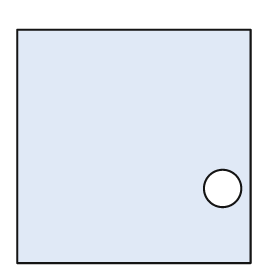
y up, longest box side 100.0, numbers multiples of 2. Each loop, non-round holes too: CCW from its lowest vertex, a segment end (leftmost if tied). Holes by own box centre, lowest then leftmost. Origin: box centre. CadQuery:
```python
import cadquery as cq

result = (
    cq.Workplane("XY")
    .moveTo(-50.0, -50.0)
    .lineTo(50.0, -50.0)
    .lineTo(50.0, 50.0)
    .lineTo(-50.0, 50.0)
    .close()
    .moveTo(38.0, -18.0)
    .circle(8.0)
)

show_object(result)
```